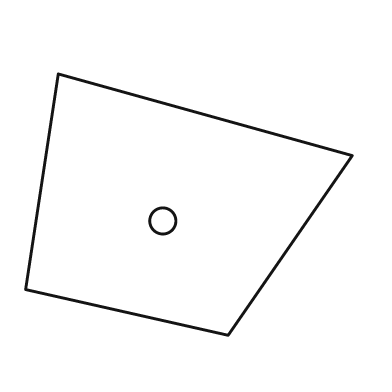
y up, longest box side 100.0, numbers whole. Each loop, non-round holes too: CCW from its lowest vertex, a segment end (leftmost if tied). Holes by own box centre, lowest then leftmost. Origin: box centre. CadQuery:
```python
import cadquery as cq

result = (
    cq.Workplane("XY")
    .moveTo(12.0, -40.0)
    .lineTo(50.0, 15.0)
    .lineTo(-40.0, 40.0)
    .lineTo(-50.0, -26.0)
    .close()
    .moveTo(-8.0, -5.0)
    .circle(4.0)
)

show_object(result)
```